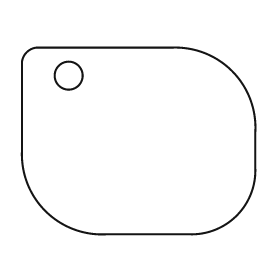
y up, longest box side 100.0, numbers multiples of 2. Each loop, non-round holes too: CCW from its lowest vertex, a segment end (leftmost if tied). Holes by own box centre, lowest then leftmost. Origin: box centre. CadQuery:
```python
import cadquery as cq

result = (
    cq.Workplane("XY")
    .moveTo(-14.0, -40.0)
    .lineTo(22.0, -40.0)
    .threePointArc((42.0, -32.0), (50.0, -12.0))
    .lineTo(50.0, 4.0)
    .threePointArc((40.0, 30.0), (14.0, 40.0))
    .lineTo(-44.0, 40.0)
    .threePointArc((-48.0, 38.0), (-50.0, 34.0))
    .lineTo(-50.0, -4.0)
    .threePointArc((-40.0, -30.0), (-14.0, -40.0))
    .close()
    .moveTo(-30.0, 28.0)
    .circle(6.0)
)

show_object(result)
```